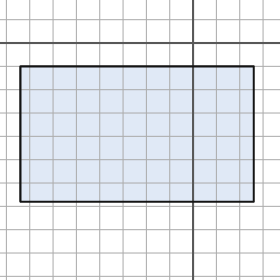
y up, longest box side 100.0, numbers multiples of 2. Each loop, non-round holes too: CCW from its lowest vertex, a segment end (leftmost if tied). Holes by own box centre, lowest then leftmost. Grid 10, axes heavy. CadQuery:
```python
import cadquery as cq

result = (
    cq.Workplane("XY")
    .moveTo(-74.0, -68.0)
    .lineTo(26.0, -68.0)
    .lineTo(26.0, -10.0)
    .lineTo(-74.0, -10.0)
    .close()
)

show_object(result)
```